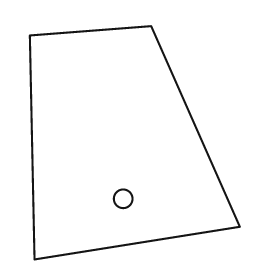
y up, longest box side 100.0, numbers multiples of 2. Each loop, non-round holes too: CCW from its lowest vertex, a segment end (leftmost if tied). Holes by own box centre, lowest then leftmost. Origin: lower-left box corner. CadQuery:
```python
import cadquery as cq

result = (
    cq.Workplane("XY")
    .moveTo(2.0, 0.0)
    .lineTo(90.0, 14.0)
    .lineTo(52.0, 100.0)
    .lineTo(0.0, 96.0)
    .close()
    .moveTo(40.0, 26.0)
    .circle(4.0)
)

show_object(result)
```